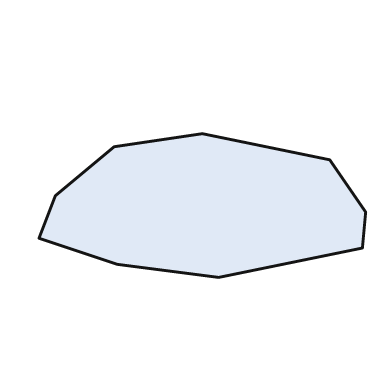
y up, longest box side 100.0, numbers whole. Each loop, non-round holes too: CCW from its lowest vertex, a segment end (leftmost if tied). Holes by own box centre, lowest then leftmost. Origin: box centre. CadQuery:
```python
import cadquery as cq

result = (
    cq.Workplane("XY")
    .moveTo(5.0, -22.0)
    .lineTo(49.0, -13.0)
    .lineTo(50.0, -2.0)
    .lineTo(39.0, 14.0)
    .lineTo(0.0, 22.0)
    .lineTo(-27.0, 18.0)
    .lineTo(-45.0, 3.0)
    .lineTo(-50.0, -10.0)
    .lineTo(-26.0, -18.0)
    .close()
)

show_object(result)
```